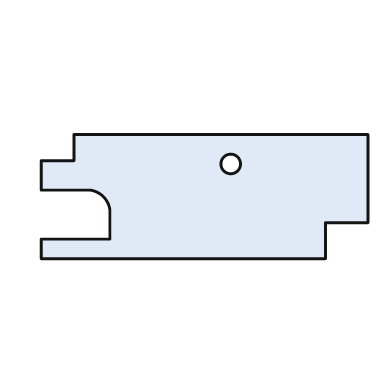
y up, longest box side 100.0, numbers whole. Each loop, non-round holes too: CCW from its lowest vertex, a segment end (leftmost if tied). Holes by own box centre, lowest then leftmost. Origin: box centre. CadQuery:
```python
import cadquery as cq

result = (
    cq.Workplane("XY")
    .moveTo(-50.0, -19.0)
    .lineTo(37.0, -19.0)
    .lineTo(37.0, -8.0)
    .lineTo(50.0, -8.0)
    .lineTo(50.0, 19.0)
    .lineTo(-40.0, 19.0)
    .lineTo(-40.0, 11.0)
    .lineTo(-50.0, 11.0)
    .lineTo(-50.0, 2.0)
    .lineTo(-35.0, 2.0)
    .threePointArc((-31.0, 0.0), (-29.0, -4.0))
    .lineTo(-29.0, -13.0)
    .lineTo(-50.0, -13.0)
    .close()
    .moveTo(8.0, 10.0)
    .circle(3.0)
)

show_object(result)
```